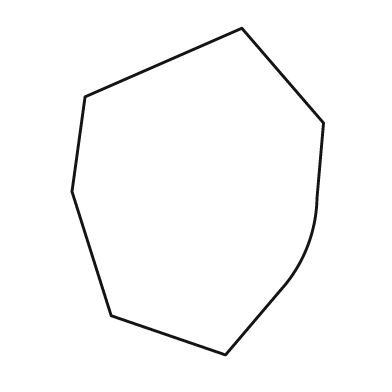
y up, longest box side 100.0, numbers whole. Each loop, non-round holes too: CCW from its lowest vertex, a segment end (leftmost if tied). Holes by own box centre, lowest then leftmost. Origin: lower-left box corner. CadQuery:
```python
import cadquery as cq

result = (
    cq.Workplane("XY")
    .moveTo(47.0, 0.0)
    .lineTo(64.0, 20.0)
    .threePointArc((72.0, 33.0), (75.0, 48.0))
    .lineTo(77.0, 71.0)
    .lineTo(52.0, 100.0)
    .lineTo(4.0, 79.0)
    .lineTo(0.0, 50.0)
    .lineTo(12.0, 12.0)
    .close()
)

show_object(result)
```